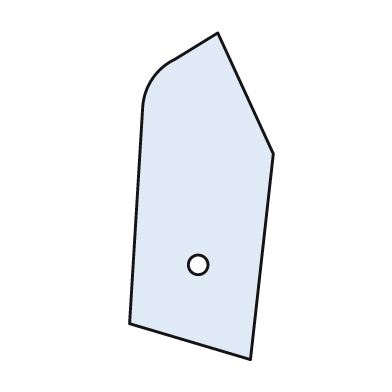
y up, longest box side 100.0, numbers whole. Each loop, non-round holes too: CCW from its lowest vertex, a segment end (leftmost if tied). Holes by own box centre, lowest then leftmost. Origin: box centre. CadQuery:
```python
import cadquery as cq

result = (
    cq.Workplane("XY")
    .moveTo(15.0, -50.0)
    .lineTo(22.0, 13.0)
    .lineTo(5.0, 50.0)
    .lineTo(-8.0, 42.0)
    .threePointArc((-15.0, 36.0), (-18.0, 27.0))
    .lineTo(-22.0, -39.0)
    .close()
    .moveTo(-1.0, -21.0)
    .circle(3.0)
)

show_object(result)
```